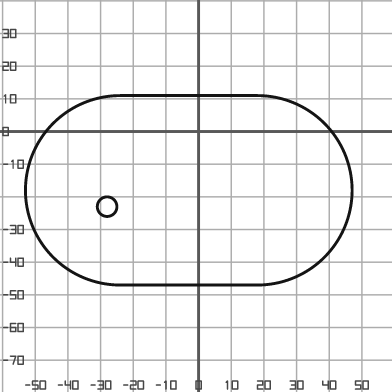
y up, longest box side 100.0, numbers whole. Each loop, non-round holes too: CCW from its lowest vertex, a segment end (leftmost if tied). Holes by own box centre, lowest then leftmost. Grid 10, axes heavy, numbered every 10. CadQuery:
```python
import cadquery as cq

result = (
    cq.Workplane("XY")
    .moveTo(-24.0, -47.0)
    .lineTo(18.0, -47.0)
    .threePointArc((47.0, -18.0), (18.0, 11.0))
    .lineTo(-24.0, 11.0)
    .threePointArc((-53.0, -18.0), (-24.0, -47.0))
    .close()
    .moveTo(-28.0, -23.0)
    .circle(3.0)
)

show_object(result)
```